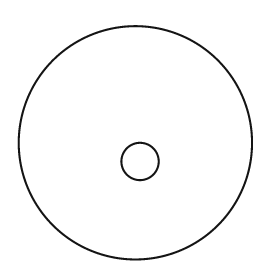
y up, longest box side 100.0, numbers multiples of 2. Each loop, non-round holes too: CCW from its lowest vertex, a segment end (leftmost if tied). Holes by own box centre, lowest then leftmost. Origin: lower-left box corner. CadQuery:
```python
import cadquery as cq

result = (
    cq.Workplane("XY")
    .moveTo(50.0, 50.0)
    .circle(50.0)
    .moveTo(52.0, 42.0)
    .circle(8.0)
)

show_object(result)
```